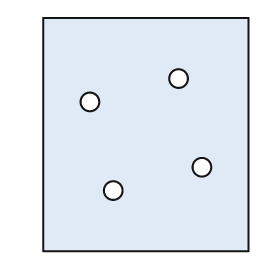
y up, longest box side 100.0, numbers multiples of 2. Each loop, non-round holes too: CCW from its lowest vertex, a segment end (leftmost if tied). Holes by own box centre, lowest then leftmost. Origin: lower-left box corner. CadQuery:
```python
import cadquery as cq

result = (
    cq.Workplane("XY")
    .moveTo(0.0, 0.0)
    .lineTo(88.0, 0.0)
    .lineTo(88.0, 100.0)
    .lineTo(0.0, 100.0)
    .close()
    .moveTo(30.0, 26.0)
    .circle(4.0)
    .moveTo(68.0, 36.0)
    .circle(4.0)
    .moveTo(20.0, 64.0)
    .circle(4.0)
    .moveTo(58.0, 74.0)
    .circle(4.0)
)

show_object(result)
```